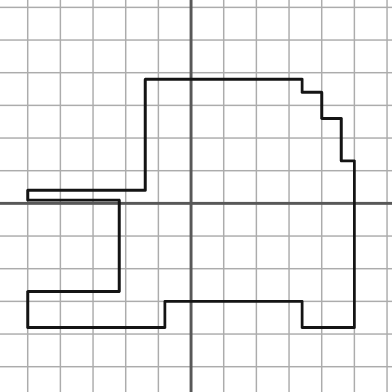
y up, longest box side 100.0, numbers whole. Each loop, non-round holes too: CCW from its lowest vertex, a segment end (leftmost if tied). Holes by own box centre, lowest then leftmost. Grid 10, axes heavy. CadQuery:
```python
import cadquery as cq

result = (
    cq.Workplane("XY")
    .moveTo(-50.0, -38.0)
    .lineTo(-8.0, -38.0)
    .lineTo(-8.0, -30.0)
    .lineTo(34.0, -30.0)
    .lineTo(34.0, -38.0)
    .lineTo(50.0, -38.0)
    .lineTo(50.0, 13.0)
    .lineTo(46.0, 13.0)
    .lineTo(46.0, 26.0)
    .lineTo(40.0, 26.0)
    .lineTo(40.0, 34.0)
    .lineTo(34.0, 34.0)
    .lineTo(34.0, 38.0)
    .lineTo(-14.0, 38.0)
    .lineTo(-14.0, 4.0)
    .lineTo(-50.0, 4.0)
    .lineTo(-50.0, 1.0)
    .lineTo(-22.0, 1.0)
    .lineTo(-22.0, -27.0)
    .lineTo(-50.0, -27.0)
    .close()
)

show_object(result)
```